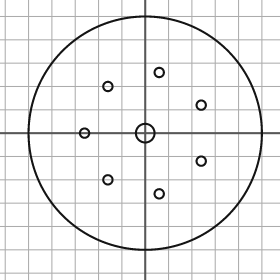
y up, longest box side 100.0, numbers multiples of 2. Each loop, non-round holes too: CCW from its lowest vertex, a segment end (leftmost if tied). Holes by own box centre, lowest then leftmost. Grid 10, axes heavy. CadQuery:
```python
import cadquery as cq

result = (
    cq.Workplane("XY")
    .moveTo(0.0, 0.0)
    .circle(50.0)
    .moveTo(6.0, -26.0)
    .circle(2.0)
    .moveTo(-16.0, -20.0)
    .circle(2.0)
    .moveTo(24.0, -12.0)
    .circle(2.0)
    .moveTo(-26.0, 0.0)
    .circle(2.0)
    .moveTo(0.0, 0.0)
    .circle(4.0)
    .moveTo(24.0, 12.0)
    .circle(2.0)
    .moveTo(-16.0, 20.0)
    .circle(2.0)
    .moveTo(6.0, 26.0)
    .circle(2.0)
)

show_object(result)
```